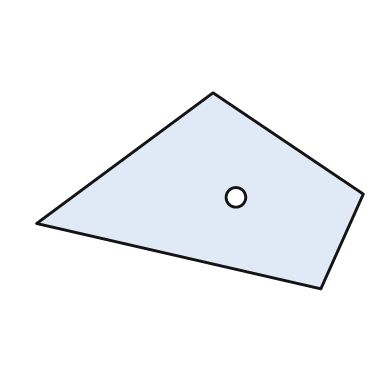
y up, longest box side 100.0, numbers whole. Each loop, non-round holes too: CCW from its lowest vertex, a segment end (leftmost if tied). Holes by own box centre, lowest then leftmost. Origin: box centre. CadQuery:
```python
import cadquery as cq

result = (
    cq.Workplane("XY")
    .moveTo(37.0, -30.0)
    .lineTo(50.0, -1.0)
    .lineTo(4.0, 30.0)
    .lineTo(-50.0, -10.0)
    .close()
    .moveTo(11.0, -2.0)
    .circle(3.0)
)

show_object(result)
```